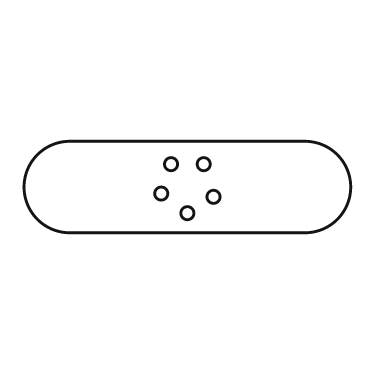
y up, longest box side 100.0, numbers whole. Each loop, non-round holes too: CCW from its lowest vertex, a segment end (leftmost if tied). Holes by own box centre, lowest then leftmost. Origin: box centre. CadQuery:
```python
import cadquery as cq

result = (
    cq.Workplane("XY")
    .moveTo(-36.0, -14.0)
    .lineTo(36.0, -14.0)
    .threePointArc((50.0, 0.0), (36.0, 14.0))
    .lineTo(-36.0, 14.0)
    .threePointArc((-50.0, 0.0), (-36.0, -14.0))
    .close()
    .moveTo(0.0, -8.0)
    .circle(2.0)
    .moveTo(8.0, -3.0)
    .circle(2.0)
    .moveTo(-8.0, -2.0)
    .circle(2.0)
    .moveTo(-5.0, 7.0)
    .circle(2.0)
    .moveTo(5.0, 7.0)
    .circle(2.0)
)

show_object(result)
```